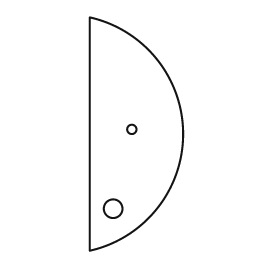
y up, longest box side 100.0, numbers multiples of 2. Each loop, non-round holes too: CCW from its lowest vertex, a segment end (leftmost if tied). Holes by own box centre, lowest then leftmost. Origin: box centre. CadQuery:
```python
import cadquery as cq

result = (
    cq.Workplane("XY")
    .moveTo(-20.0, -50.0)
    .threePointArc((20.0, 0.0), (-20.0, 50.0))
    .close()
    .moveTo(-10.0, -32.0)
    .circle(4.0)
    .moveTo(-2.0, 2.0)
    .circle(2.0)
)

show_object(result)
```